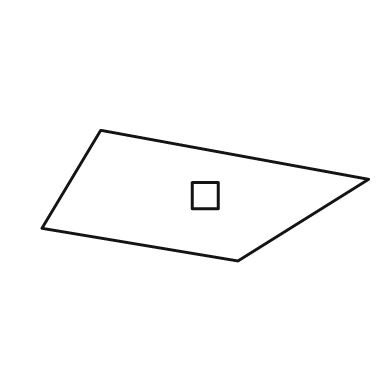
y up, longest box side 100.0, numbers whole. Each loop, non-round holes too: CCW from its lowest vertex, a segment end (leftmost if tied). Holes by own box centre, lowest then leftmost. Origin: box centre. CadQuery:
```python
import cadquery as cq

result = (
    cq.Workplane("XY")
    .moveTo(10.0, -20.0)
    .lineTo(50.0, 5.0)
    .lineTo(-32.0, 20.0)
    .lineTo(-50.0, -10.0)
    .close()
    .moveTo(-4.0, -4.0)
    .lineTo(4.0, -4.0)
    .lineTo(4.0, 4.0)
    .lineTo(-4.0, 4.0)
    .close()
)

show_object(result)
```